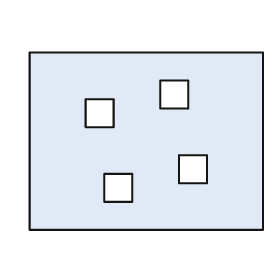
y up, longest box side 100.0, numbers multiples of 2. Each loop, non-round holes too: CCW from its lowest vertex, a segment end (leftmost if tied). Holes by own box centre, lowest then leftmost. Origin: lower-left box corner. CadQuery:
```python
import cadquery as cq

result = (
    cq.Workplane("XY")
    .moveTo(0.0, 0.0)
    .lineTo(100.0, 0.0)
    .lineTo(100.0, 76.0)
    .lineTo(0.0, 76.0)
    .close()
    .moveTo(32.0, 12.0)
    .lineTo(44.0, 12.0)
    .lineTo(44.0, 24.0)
    .lineTo(32.0, 24.0)
    .close()
    .moveTo(64.0, 20.0)
    .lineTo(76.0, 20.0)
    .lineTo(76.0, 32.0)
    .lineTo(64.0, 32.0)
    .close()
    .moveTo(24.0, 44.0)
    .lineTo(36.0, 44.0)
    .lineTo(36.0, 56.0)
    .lineTo(24.0, 56.0)
    .close()
    .moveTo(56.0, 52.0)
    .lineTo(68.0, 52.0)
    .lineTo(68.0, 64.0)
    .lineTo(56.0, 64.0)
    .close()
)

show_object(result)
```